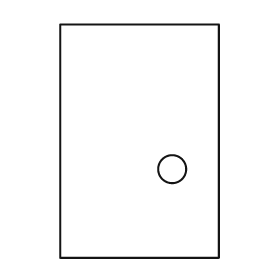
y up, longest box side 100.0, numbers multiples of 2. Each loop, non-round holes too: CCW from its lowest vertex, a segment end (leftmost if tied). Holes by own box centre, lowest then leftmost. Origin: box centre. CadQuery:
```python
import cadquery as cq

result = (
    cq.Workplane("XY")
    .moveTo(-34.0, -50.0)
    .lineTo(34.0, -50.0)
    .lineTo(34.0, 50.0)
    .lineTo(-34.0, 50.0)
    .close()
    .moveTo(14.0, -12.0)
    .circle(6.0)
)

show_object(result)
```